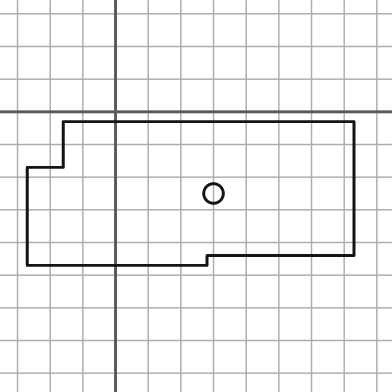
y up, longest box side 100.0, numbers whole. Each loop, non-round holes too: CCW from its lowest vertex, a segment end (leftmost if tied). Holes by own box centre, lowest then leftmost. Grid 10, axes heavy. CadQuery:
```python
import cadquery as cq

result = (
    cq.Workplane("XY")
    .moveTo(-27.0, -47.0)
    .lineTo(28.0, -47.0)
    .lineTo(28.0, -44.0)
    .lineTo(73.0, -44.0)
    .lineTo(73.0, -3.0)
    .lineTo(-16.0, -3.0)
    .lineTo(-16.0, -17.0)
    .lineTo(-27.0, -17.0)
    .close()
    .moveTo(30.0, -25.0)
    .circle(3.0)
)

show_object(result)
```